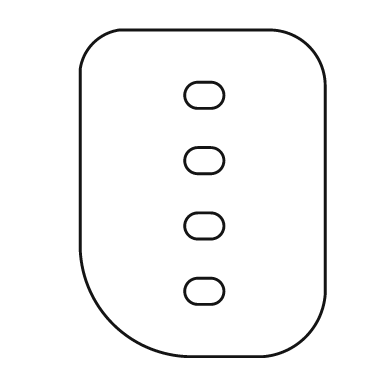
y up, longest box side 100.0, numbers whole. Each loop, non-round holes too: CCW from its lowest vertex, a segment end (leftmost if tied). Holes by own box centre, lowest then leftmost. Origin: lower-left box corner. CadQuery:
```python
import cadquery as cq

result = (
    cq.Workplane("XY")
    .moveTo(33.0, 0.0)
    .lineTo(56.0, 0.0)
    .threePointArc((69.0, 6.0), (75.0, 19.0))
    .lineTo(75.0, 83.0)
    .threePointArc((70.0, 95.0), (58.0, 100.0))
    .lineTo(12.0, 100.0)
    .threePointArc((4.0, 96.0), (0.0, 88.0))
    .lineTo(0.0, 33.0)
    .threePointArc((10.0, 10.0), (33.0, 0.0))
    .close()
    .moveTo(36.0, 16.0)
    .lineTo(40.0, 16.0)
    .threePointArc((44.0, 20.0), (40.0, 24.0))
    .lineTo(36.0, 24.0)
    .threePointArc((32.0, 20.0), (36.0, 16.0))
    .close()
    .moveTo(36.0, 36.0)
    .lineTo(40.0, 36.0)
    .threePointArc((44.0, 40.0), (40.0, 44.0))
    .lineTo(36.0, 44.0)
    .threePointArc((32.0, 40.0), (36.0, 36.0))
    .close()
    .moveTo(36.0, 56.0)
    .lineTo(40.0, 56.0)
    .threePointArc((44.0, 60.0), (40.0, 64.0))
    .lineTo(36.0, 64.0)
    .threePointArc((32.0, 60.0), (36.0, 56.0))
    .close()
    .moveTo(36.0, 76.0)
    .lineTo(40.0, 76.0)
    .threePointArc((44.0, 80.0), (40.0, 84.0))
    .lineTo(36.0, 84.0)
    .threePointArc((32.0, 80.0), (36.0, 76.0))
    .close()
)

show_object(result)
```